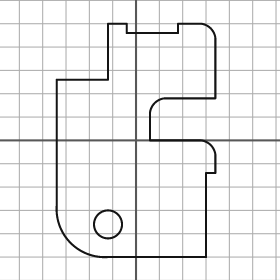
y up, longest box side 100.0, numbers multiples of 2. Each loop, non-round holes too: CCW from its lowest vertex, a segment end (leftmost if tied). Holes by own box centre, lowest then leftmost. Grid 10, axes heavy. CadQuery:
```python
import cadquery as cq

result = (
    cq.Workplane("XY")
    .moveTo(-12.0, -50.0)
    .lineTo(30.0, -50.0)
    .lineTo(30.0, -14.0)
    .lineTo(34.0, -14.0)
    .lineTo(34.0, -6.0)
    .threePointArc((32.0, -2.0), (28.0, 0.0))
    .lineTo(6.0, 0.0)
    .lineTo(6.0, 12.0)
    .threePointArc((8.0, 16.0), (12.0, 18.0))
    .lineTo(34.0, 18.0)
    .lineTo(34.0, 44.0)
    .threePointArc((32.0, 48.0), (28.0, 50.0))
    .lineTo(18.0, 50.0)
    .lineTo(18.0, 46.0)
    .lineTo(-4.0, 46.0)
    .lineTo(-4.0, 50.0)
    .lineTo(-12.0, 50.0)
    .lineTo(-12.0, 26.0)
    .lineTo(-34.0, 26.0)
    .lineTo(-34.0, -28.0)
    .threePointArc((-28.0, -44.0), (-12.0, -50.0))
    .close()
    .moveTo(-12.0, -36.0)
    .circle(6.0)
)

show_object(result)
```